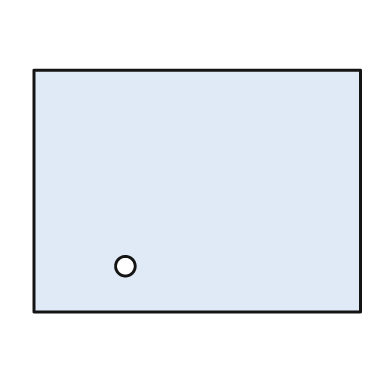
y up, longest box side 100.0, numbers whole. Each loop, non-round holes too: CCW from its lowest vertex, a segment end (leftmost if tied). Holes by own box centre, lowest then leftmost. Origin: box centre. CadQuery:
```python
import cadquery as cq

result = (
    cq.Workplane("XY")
    .moveTo(-50.0, -37.0)
    .lineTo(50.0, -37.0)
    .lineTo(50.0, 37.0)
    .lineTo(-50.0, 37.0)
    .close()
    .moveTo(-22.0, -23.0)
    .circle(3.0)
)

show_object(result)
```